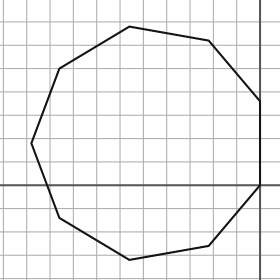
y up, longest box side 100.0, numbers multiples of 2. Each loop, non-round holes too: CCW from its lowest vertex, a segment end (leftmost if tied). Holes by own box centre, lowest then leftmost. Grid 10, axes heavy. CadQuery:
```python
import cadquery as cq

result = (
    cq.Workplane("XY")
    .moveTo(-56.0, -32.0)
    .lineTo(-22.0, -26.0)
    .lineTo(0.0, 0.0)
    .lineTo(0.0, 36.0)
    .lineTo(-22.0, 62.0)
    .lineTo(-56.0, 68.0)
    .lineTo(-86.0, 50.0)
    .lineTo(-98.0, 18.0)
    .lineTo(-86.0, -14.0)
    .close()
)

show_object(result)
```